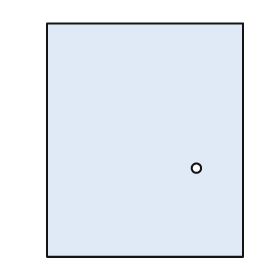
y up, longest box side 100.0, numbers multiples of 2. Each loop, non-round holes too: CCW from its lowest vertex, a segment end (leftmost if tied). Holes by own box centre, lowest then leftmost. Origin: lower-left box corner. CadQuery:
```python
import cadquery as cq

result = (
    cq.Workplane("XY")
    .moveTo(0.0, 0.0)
    .lineTo(84.0, 0.0)
    .lineTo(84.0, 100.0)
    .lineTo(0.0, 100.0)
    .close()
    .moveTo(64.0, 38.0)
    .circle(2.0)
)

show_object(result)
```